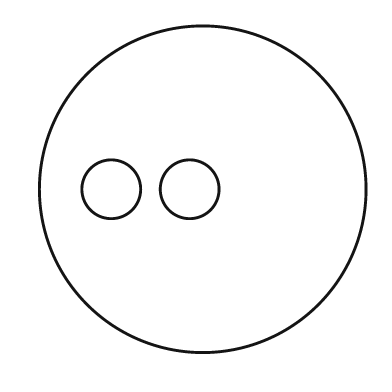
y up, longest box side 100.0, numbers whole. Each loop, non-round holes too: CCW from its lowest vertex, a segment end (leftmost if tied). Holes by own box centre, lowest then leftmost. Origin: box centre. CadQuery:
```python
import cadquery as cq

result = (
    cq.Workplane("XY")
    .moveTo(0.0, 0.0)
    .circle(50.0)
    .moveTo(-28.0, 0.0)
    .circle(9.0)
    .moveTo(-4.0, 0.0)
    .circle(9.0)
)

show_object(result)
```